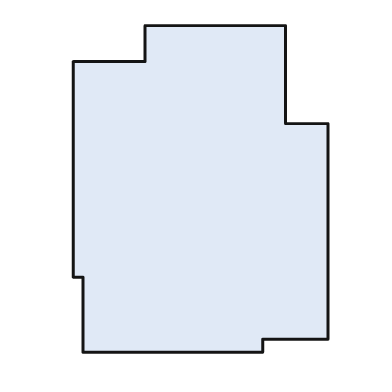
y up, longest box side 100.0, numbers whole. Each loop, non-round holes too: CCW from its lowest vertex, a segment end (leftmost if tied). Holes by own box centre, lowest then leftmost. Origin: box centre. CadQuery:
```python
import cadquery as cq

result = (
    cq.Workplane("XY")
    .moveTo(-36.0, -50.0)
    .lineTo(19.0, -50.0)
    .lineTo(19.0, -46.0)
    .lineTo(39.0, -46.0)
    .lineTo(39.0, 20.0)
    .lineTo(26.0, 20.0)
    .lineTo(26.0, 50.0)
    .lineTo(-17.0, 50.0)
    .lineTo(-17.0, 39.0)
    .lineTo(-39.0, 39.0)
    .lineTo(-39.0, -27.0)
    .lineTo(-36.0, -27.0)
    .close()
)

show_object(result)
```